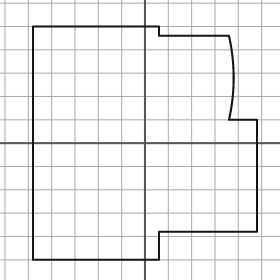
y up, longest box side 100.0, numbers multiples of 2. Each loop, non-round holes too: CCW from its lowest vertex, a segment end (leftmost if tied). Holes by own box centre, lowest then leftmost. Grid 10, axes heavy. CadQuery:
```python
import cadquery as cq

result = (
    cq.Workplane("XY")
    .moveTo(-48.0, -50.0)
    .lineTo(6.0, -50.0)
    .lineTo(6.0, -38.0)
    .lineTo(48.0, -38.0)
    .lineTo(48.0, 10.0)
    .lineTo(36.0, 10.0)
    .threePointArc((38.0, 28.0), (36.0, 46.0))
    .lineTo(6.0, 46.0)
    .lineTo(6.0, 50.0)
    .lineTo(-48.0, 50.0)
    .close()
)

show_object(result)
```